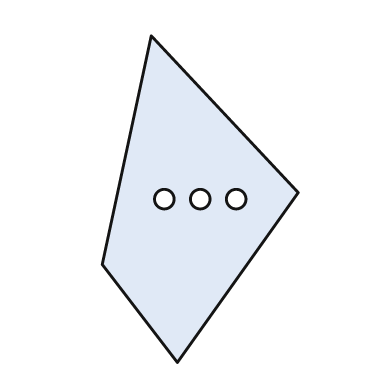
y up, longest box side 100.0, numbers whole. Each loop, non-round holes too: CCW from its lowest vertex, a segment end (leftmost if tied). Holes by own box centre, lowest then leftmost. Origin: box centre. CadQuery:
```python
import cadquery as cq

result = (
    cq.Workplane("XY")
    .moveTo(-7.0, -50.0)
    .lineTo(30.0, 2.0)
    .lineTo(-15.0, 50.0)
    .lineTo(-30.0, -20.0)
    .close()
    .moveTo(-11.0, 0.0)
    .circle(3.0)
    .moveTo(0.0, 0.0)
    .circle(3.0)
    .moveTo(11.0, 0.0)
    .circle(3.0)
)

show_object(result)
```